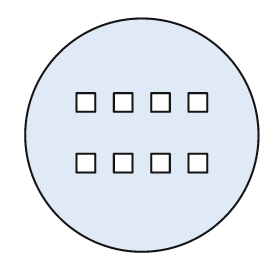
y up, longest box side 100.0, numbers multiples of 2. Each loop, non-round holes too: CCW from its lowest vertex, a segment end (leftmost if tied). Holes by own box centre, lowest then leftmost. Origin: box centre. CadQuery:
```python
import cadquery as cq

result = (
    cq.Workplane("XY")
    .moveTo(0.0, 0.0)
    .circle(50.0)
    .moveTo(-28.0, -16.0)
    .lineTo(-20.0, -16.0)
    .lineTo(-20.0, -8.0)
    .lineTo(-28.0, -8.0)
    .close()
    .moveTo(-12.0, -16.0)
    .lineTo(-4.0, -16.0)
    .lineTo(-4.0, -8.0)
    .lineTo(-12.0, -8.0)
    .close()
    .moveTo(4.0, -16.0)
    .lineTo(12.0, -16.0)
    .lineTo(12.0, -8.0)
    .lineTo(4.0, -8.0)
    .close()
    .moveTo(20.0, -16.0)
    .lineTo(28.0, -16.0)
    .lineTo(28.0, -8.0)
    .lineTo(20.0, -8.0)
    .close()
    .moveTo(-28.0, 10.0)
    .lineTo(-20.0, 10.0)
    .lineTo(-20.0, 18.0)
    .lineTo(-28.0, 18.0)
    .close()
    .moveTo(-12.0, 10.0)
    .lineTo(-4.0, 10.0)
    .lineTo(-4.0, 18.0)
    .lineTo(-12.0, 18.0)
    .close()
    .moveTo(4.0, 10.0)
    .lineTo(12.0, 10.0)
    .lineTo(12.0, 18.0)
    .lineTo(4.0, 18.0)
    .close()
    .moveTo(20.0, 10.0)
    .lineTo(28.0, 10.0)
    .lineTo(28.0, 18.0)
    .lineTo(20.0, 18.0)
    .close()
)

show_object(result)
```